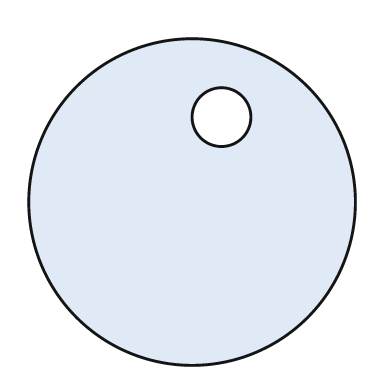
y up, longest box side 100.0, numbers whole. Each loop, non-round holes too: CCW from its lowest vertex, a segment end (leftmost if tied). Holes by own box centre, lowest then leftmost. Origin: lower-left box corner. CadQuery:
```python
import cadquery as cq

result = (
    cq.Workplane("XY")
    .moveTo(50.0, 50.0)
    .circle(50.0)
    .moveTo(59.0, 76.0)
    .circle(9.0)
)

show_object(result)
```